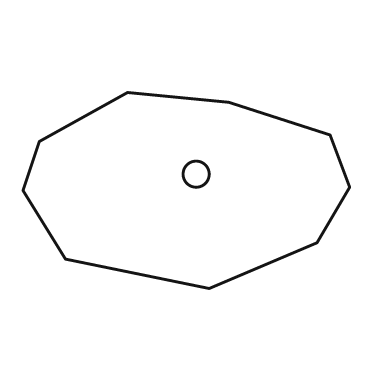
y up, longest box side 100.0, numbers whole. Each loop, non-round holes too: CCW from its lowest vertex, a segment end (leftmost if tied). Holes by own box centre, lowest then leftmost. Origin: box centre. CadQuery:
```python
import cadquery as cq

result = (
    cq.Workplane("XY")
    .moveTo(7.0, -30.0)
    .lineTo(40.0, -16.0)
    .lineTo(50.0, 1.0)
    .lineTo(44.0, 17.0)
    .lineTo(13.0, 27.0)
    .lineTo(-18.0, 30.0)
    .lineTo(-45.0, 15.0)
    .lineTo(-50.0, 0.0)
    .lineTo(-37.0, -21.0)
    .close()
    .moveTo(3.0, 5.0)
    .circle(4.0)
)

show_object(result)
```